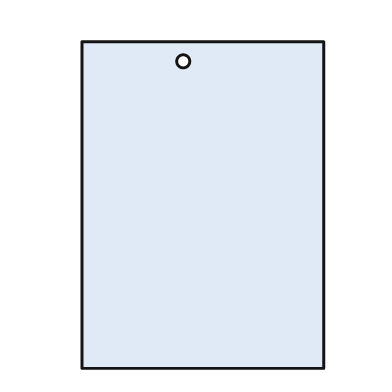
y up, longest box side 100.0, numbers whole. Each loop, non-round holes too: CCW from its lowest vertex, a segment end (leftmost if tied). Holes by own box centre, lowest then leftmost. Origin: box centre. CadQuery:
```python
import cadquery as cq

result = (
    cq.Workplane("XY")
    .moveTo(-37.0, -50.0)
    .lineTo(37.0, -50.0)
    .lineTo(37.0, 50.0)
    .lineTo(-37.0, 50.0)
    .close()
    .moveTo(-6.0, 44.0)
    .circle(2.0)
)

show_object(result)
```